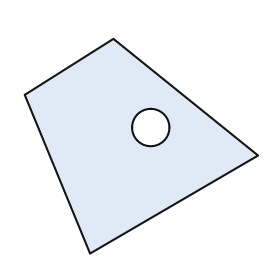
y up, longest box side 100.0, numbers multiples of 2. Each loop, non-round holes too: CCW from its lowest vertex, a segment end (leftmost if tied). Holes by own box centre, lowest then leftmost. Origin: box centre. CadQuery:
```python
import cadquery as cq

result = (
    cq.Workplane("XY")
    .moveTo(-22.0, -46.0)
    .lineTo(50.0, -4.0)
    .lineTo(-12.0, 46.0)
    .lineTo(-50.0, 22.0)
    .close()
    .moveTo(4.0, 8.0)
    .circle(8.0)
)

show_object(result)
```